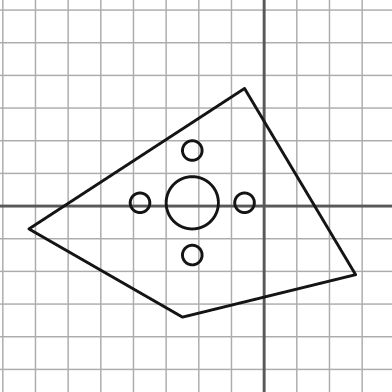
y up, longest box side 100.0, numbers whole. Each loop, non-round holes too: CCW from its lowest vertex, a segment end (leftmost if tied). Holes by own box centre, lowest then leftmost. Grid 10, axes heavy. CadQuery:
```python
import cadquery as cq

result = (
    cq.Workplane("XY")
    .moveTo(-25.0, -34.0)
    .lineTo(28.0, -21.0)
    .lineTo(-6.0, 36.0)
    .lineTo(-72.0, -7.0)
    .close()
    .moveTo(-22.0, -15.0)
    .circle(3.0)
    .moveTo(-38.0, 1.0)
    .circle(3.0)
    .moveTo(-22.0, 1.0)
    .circle(8.0)
    .moveTo(-6.0, 1.0)
    .circle(3.0)
    .moveTo(-22.0, 17.0)
    .circle(3.0)
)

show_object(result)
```